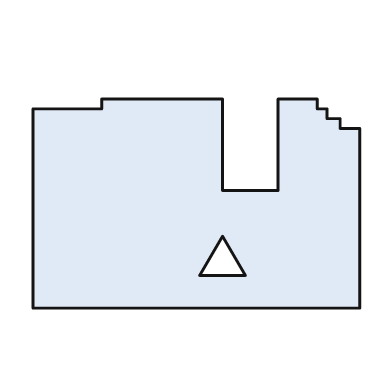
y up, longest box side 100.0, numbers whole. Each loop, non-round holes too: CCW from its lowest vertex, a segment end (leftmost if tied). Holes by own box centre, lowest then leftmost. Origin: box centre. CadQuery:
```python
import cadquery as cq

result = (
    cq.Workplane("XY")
    .moveTo(-50.0, -32.0)
    .lineTo(50.0, -32.0)
    .lineTo(50.0, 23.0)
    .lineTo(44.0, 23.0)
    .lineTo(44.0, 26.0)
    .lineTo(40.0, 26.0)
    .lineTo(40.0, 29.0)
    .lineTo(37.0, 29.0)
    .lineTo(37.0, 32.0)
    .lineTo(25.0, 32.0)
    .lineTo(25.0, 4.0)
    .lineTo(8.0, 4.0)
    .lineTo(8.0, 32.0)
    .lineTo(-29.0, 32.0)
    .lineTo(-29.0, 29.0)
    .lineTo(-50.0, 29.0)
    .close()
    .moveTo(1.0, -22.0)
    .lineTo(15.0, -22.0)
    .lineTo(8.0, -10.0)
    .close()
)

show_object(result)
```